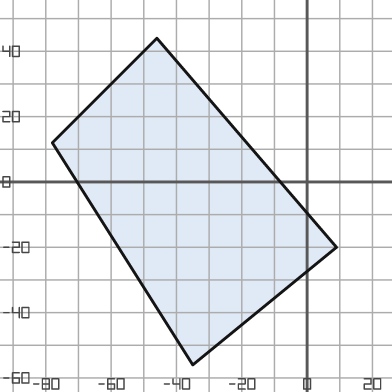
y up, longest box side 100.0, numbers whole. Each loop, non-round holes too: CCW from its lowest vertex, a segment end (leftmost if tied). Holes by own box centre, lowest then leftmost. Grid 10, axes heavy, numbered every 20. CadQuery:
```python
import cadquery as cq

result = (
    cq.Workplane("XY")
    .moveTo(-35.0, -56.0)
    .lineTo(9.0, -20.0)
    .lineTo(-46.0, 44.0)
    .lineTo(-78.0, 12.0)
    .close()
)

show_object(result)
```